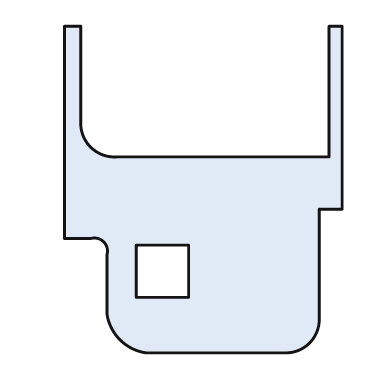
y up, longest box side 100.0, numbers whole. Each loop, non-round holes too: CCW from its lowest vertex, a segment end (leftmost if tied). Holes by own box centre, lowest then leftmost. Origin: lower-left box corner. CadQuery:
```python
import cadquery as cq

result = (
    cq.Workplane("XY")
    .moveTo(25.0, 0.0)
    .lineTo(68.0, 0.0)
    .threePointArc((75.0, 3.0), (78.0, 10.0))
    .lineTo(78.0, 44.0)
    .lineTo(85.0, 44.0)
    .lineTo(85.0, 100.0)
    .lineTo(81.0, 100.0)
    .lineTo(81.0, 60.0)
    .lineTo(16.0, 60.0)
    .threePointArc((8.0, 63.0), (5.0, 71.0))
    .lineTo(5.0, 100.0)
    .lineTo(0.0, 100.0)
    .lineTo(0.0, 35.0)
    .lineTo(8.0, 35.0)
    .threePointArc((12.0, 34.0), (13.0, 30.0))
    .lineTo(13.0, 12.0)
    .threePointArc((17.0, 4.0), (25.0, 0.0))
    .close()
    .moveTo(22.0, 17.0)
    .lineTo(38.0, 17.0)
    .lineTo(38.0, 33.0)
    .lineTo(22.0, 33.0)
    .close()
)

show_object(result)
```